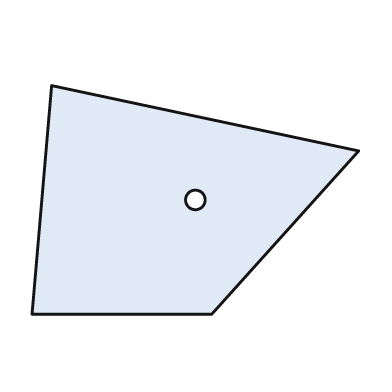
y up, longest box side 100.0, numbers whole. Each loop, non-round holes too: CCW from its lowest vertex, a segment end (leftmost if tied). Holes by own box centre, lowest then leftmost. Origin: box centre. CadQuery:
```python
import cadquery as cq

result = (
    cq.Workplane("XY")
    .moveTo(-50.0, -35.0)
    .lineTo(5.0, -35.0)
    .lineTo(50.0, 15.0)
    .lineTo(-44.0, 35.0)
    .close()
    .moveTo(0.0, 0.0)
    .circle(3.0)
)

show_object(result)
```